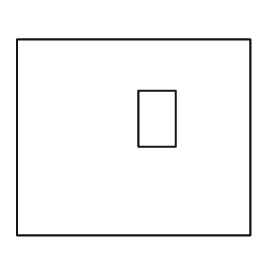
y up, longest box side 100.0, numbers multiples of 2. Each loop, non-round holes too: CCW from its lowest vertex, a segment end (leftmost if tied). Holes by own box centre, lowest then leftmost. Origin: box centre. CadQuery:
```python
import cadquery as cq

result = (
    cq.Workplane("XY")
    .moveTo(-50.0, -42.0)
    .lineTo(50.0, -42.0)
    .lineTo(50.0, 42.0)
    .lineTo(-50.0, 42.0)
    .close()
    .moveTo(2.0, -4.0)
    .lineTo(18.0, -4.0)
    .lineTo(18.0, 20.0)
    .lineTo(2.0, 20.0)
    .close()
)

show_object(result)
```